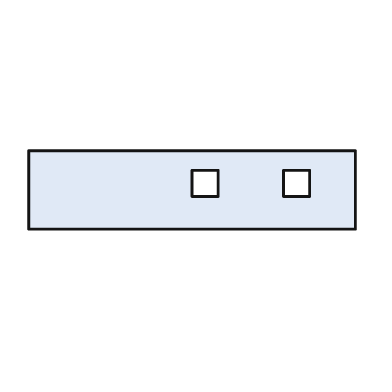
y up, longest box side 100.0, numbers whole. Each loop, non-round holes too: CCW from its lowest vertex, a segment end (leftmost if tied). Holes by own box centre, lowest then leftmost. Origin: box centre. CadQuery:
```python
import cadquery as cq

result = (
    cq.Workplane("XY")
    .moveTo(-50.0, -12.0)
    .lineTo(50.0, -12.0)
    .lineTo(50.0, 12.0)
    .lineTo(-50.0, 12.0)
    .close()
    .moveTo(0.0, -2.0)
    .lineTo(8.0, -2.0)
    .lineTo(8.0, 6.0)
    .lineTo(0.0, 6.0)
    .close()
    .moveTo(28.0, -2.0)
    .lineTo(36.0, -2.0)
    .lineTo(36.0, 6.0)
    .lineTo(28.0, 6.0)
    .close()
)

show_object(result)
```